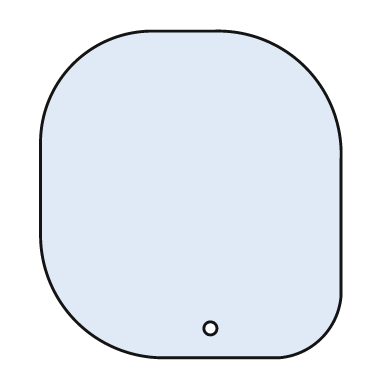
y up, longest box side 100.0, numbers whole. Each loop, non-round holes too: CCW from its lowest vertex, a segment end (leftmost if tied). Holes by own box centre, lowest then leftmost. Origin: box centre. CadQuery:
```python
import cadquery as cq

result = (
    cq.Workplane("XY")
    .moveTo(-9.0, -50.0)
    .lineTo(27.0, -50.0)
    .threePointArc((40.0, -44.0), (46.0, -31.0))
    .lineTo(46.0, 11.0)
    .threePointArc((35.0, 39.0), (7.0, 50.0))
    .lineTo(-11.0, 50.0)
    .threePointArc((-36.0, 40.0), (-46.0, 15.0))
    .lineTo(-46.0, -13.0)
    .threePointArc((-35.0, -39.0), (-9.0, -50.0))
    .close()
    .moveTo(6.0, -41.0)
    .circle(2.0)
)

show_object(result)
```